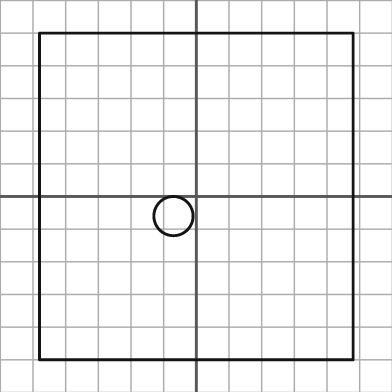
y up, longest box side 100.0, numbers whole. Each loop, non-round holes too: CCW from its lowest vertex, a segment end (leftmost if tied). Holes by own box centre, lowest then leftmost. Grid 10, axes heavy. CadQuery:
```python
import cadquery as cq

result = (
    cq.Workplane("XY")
    .moveTo(-48.0, -50.0)
    .lineTo(48.0, -50.0)
    .lineTo(48.0, 50.0)
    .lineTo(-48.0, 50.0)
    .close()
    .moveTo(-7.0, -6.0)
    .circle(6.0)
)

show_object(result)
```